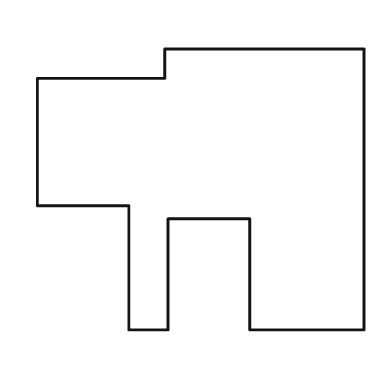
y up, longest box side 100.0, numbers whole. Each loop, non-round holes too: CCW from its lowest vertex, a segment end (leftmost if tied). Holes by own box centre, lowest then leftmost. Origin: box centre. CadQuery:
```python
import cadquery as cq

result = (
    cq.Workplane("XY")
    .moveTo(-22.0, -43.0)
    .lineTo(-10.0, -43.0)
    .lineTo(-10.0, -9.0)
    .lineTo(15.0, -9.0)
    .lineTo(15.0, -43.0)
    .lineTo(50.0, -43.0)
    .lineTo(50.0, 43.0)
    .lineTo(-11.0, 43.0)
    .lineTo(-11.0, 34.0)
    .lineTo(-50.0, 34.0)
    .lineTo(-50.0, -5.0)
    .lineTo(-22.0, -5.0)
    .close()
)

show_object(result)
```